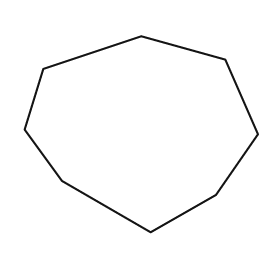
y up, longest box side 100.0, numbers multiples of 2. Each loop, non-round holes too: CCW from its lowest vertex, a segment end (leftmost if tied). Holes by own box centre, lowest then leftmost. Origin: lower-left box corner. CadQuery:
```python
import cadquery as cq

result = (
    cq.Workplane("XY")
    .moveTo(54.0, 0.0)
    .lineTo(82.0, 16.0)
    .lineTo(100.0, 42.0)
    .lineTo(86.0, 74.0)
    .lineTo(50.0, 84.0)
    .lineTo(8.0, 70.0)
    .lineTo(0.0, 44.0)
    .lineTo(16.0, 22.0)
    .close()
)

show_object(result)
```